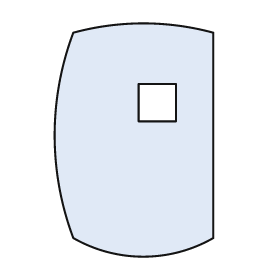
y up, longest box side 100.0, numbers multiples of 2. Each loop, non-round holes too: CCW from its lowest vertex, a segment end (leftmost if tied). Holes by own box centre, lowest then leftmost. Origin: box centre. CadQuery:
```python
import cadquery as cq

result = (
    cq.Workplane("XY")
    .moveTo(-26.0, -42.0)
    .threePointArc((4.0, -50.0), (34.0, -42.0))
    .lineTo(34.0, 46.0)
    .threePointArc((4.0, 50.0), (-26.0, 46.0))
    .threePointArc((-34.0, 2.0), (-26.0, -42.0))
    .close()
    .moveTo(2.0, 8.0)
    .lineTo(18.0, 8.0)
    .lineTo(18.0, 24.0)
    .lineTo(2.0, 24.0)
    .close()
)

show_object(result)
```